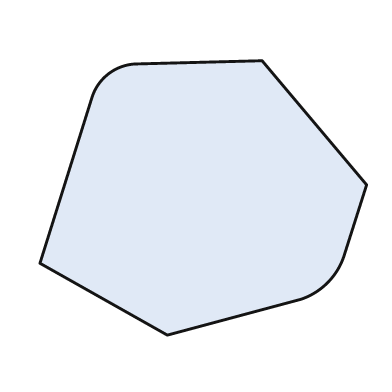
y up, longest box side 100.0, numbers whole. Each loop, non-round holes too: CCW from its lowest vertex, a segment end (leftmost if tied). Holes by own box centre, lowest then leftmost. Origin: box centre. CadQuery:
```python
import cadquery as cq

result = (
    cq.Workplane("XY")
    .moveTo(-11.0, -42.0)
    .lineTo(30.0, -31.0)
    .threePointArc((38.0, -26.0), (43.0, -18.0))
    .lineTo(50.0, 4.0)
    .lineTo(18.0, 42.0)
    .lineTo(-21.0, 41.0)
    .threePointArc((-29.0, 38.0), (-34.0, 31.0))
    .lineTo(-50.0, -20.0)
    .close()
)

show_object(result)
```